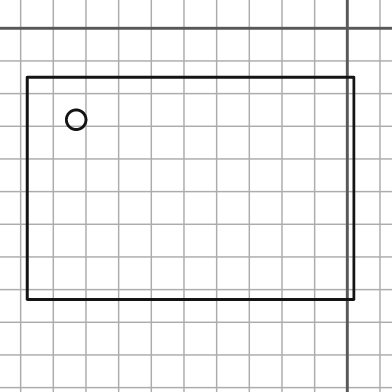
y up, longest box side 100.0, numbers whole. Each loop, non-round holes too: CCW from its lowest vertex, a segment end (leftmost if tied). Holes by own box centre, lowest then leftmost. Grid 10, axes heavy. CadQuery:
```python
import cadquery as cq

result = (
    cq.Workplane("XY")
    .moveTo(-98.0, -83.0)
    .lineTo(2.0, -83.0)
    .lineTo(2.0, -15.0)
    .lineTo(-98.0, -15.0)
    .close()
    .moveTo(-83.0, -28.0)
    .circle(3.0)
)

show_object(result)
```